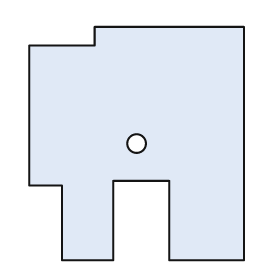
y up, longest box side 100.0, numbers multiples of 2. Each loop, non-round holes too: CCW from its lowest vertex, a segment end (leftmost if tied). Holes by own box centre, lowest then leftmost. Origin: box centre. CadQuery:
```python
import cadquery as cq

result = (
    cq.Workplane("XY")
    .moveTo(-32.0, -50.0)
    .lineTo(-10.0, -50.0)
    .lineTo(-10.0, -16.0)
    .lineTo(14.0, -16.0)
    .lineTo(14.0, -50.0)
    .lineTo(46.0, -50.0)
    .lineTo(46.0, 50.0)
    .lineTo(-18.0, 50.0)
    .lineTo(-18.0, 42.0)
    .lineTo(-46.0, 42.0)
    .lineTo(-46.0, -18.0)
    .lineTo(-32.0, -18.0)
    .close()
    .moveTo(0.0, 0.0)
    .circle(4.0)
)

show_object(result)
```